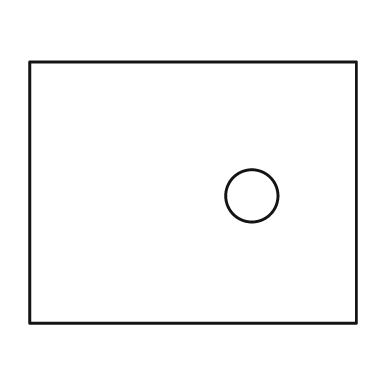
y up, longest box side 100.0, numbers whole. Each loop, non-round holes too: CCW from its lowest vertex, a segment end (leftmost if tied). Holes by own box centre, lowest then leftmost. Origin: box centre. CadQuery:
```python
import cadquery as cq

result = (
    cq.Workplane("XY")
    .moveTo(-50.0, -40.0)
    .lineTo(50.0, -40.0)
    .lineTo(50.0, 40.0)
    .lineTo(-50.0, 40.0)
    .close()
    .moveTo(18.0, -1.0)
    .circle(8.0)
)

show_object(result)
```